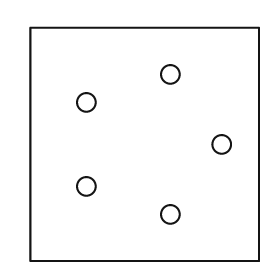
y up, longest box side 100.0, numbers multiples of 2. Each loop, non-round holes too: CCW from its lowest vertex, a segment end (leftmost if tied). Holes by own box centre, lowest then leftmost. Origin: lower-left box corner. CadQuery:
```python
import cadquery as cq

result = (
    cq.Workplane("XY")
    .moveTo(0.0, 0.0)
    .lineTo(98.0, 0.0)
    .lineTo(98.0, 100.0)
    .lineTo(0.0, 100.0)
    .close()
    .moveTo(60.0, 20.0)
    .circle(4.0)
    .moveTo(24.0, 32.0)
    .circle(4.0)
    .moveTo(82.0, 50.0)
    .circle(4.0)
    .moveTo(24.0, 68.0)
    .circle(4.0)
    .moveTo(60.0, 80.0)
    .circle(4.0)
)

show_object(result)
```